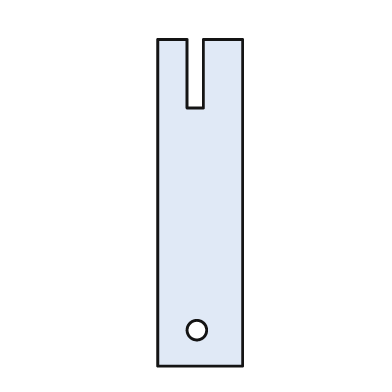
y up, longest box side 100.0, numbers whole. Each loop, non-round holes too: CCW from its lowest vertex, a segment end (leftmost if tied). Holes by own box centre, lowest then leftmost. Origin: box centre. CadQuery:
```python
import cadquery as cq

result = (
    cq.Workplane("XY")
    .moveTo(-13.0, -50.0)
    .lineTo(13.0, -50.0)
    .lineTo(13.0, 50.0)
    .lineTo(1.0, 50.0)
    .lineTo(1.0, 29.0)
    .lineTo(-4.0, 29.0)
    .lineTo(-4.0, 50.0)
    .lineTo(-13.0, 50.0)
    .close()
    .moveTo(-1.0, -39.0)
    .circle(3.0)
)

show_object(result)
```